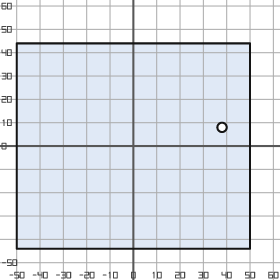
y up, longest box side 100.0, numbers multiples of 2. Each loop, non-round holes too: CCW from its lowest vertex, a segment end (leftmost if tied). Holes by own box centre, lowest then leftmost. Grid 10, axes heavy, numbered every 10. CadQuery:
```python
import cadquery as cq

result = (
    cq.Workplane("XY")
    .moveTo(-50.0, -44.0)
    .lineTo(50.0, -44.0)
    .lineTo(50.0, 44.0)
    .lineTo(-50.0, 44.0)
    .close()
    .moveTo(38.0, 8.0)
    .circle(2.0)
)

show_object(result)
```